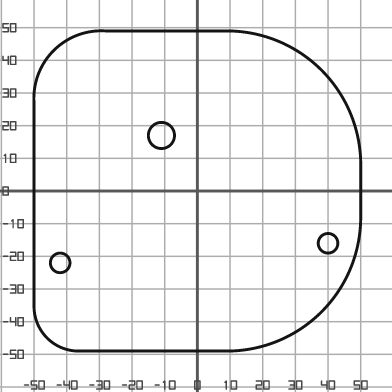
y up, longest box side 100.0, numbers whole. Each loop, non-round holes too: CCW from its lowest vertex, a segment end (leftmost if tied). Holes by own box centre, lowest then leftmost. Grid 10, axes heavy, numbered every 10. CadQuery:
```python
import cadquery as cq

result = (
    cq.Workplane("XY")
    .moveTo(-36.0, -49.0)
    .lineTo(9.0, -49.0)
    .threePointArc((38.0, -37.0), (50.0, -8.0))
    .lineTo(50.0, 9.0)
    .threePointArc((38.0, 37.0), (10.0, 49.0))
    .lineTo(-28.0, 49.0)
    .threePointArc((-44.0, 43.0), (-50.0, 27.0))
    .lineTo(-50.0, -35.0)
    .threePointArc((-46.0, -45.0), (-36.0, -49.0))
    .close()
    .moveTo(-42.0, -22.0)
    .circle(3.0)
    .moveTo(40.0, -16.0)
    .circle(3.0)
    .moveTo(-11.0, 17.0)
    .circle(4.0)
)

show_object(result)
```